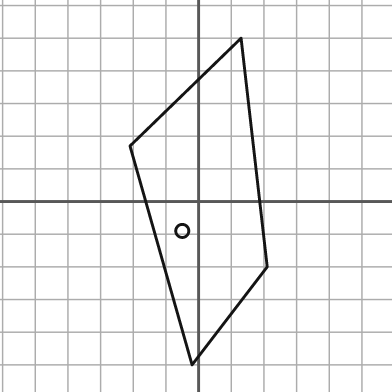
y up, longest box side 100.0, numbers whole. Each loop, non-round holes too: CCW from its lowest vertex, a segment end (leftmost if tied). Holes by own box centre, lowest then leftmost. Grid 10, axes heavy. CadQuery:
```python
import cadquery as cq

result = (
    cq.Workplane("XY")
    .moveTo(-2.0, -50.0)
    .lineTo(21.0, -20.0)
    .lineTo(13.0, 50.0)
    .lineTo(-21.0, 17.0)
    .close()
    .moveTo(-5.0, -9.0)
    .circle(2.0)
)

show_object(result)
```